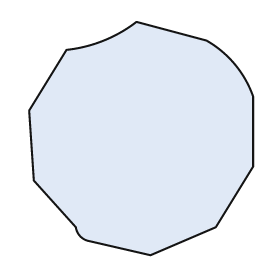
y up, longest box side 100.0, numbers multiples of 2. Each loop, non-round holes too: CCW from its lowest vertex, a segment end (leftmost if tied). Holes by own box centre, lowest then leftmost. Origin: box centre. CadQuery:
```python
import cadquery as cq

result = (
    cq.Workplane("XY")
    .moveTo(4.0, -50.0)
    .lineTo(32.0, -38.0)
    .lineTo(48.0, -12.0)
    .lineTo(48.0, 18.0)
    .threePointArc((40.0, 32.0), (28.0, 42.0))
    .lineTo(-2.0, 50.0)
    .threePointArc((-16.0, 42.0), (-32.0, 38.0))
    .lineTo(-48.0, 12.0)
    .lineTo(-46.0, -18.0)
    .lineTo(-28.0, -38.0)
    .threePointArc((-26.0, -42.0), (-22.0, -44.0))
    .close()
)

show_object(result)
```